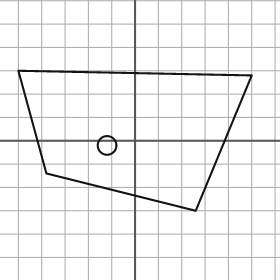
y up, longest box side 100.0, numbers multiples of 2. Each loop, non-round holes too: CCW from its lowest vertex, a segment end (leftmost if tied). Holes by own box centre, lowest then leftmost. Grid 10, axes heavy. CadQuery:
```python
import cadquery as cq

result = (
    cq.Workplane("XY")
    .moveTo(26.0, -30.0)
    .lineTo(50.0, 28.0)
    .lineTo(-50.0, 30.0)
    .lineTo(-38.0, -14.0)
    .close()
    .moveTo(-12.0, -2.0)
    .circle(4.0)
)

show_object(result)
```